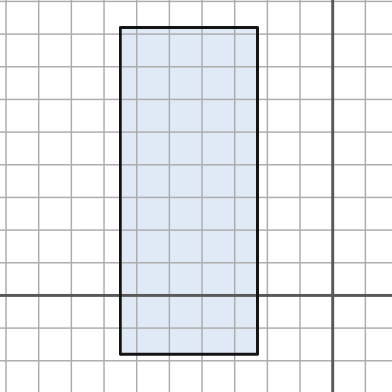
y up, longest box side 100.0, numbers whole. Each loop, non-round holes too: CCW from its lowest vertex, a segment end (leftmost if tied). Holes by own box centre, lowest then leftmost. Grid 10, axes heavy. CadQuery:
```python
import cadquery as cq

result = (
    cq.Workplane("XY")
    .moveTo(-65.0, -18.0)
    .lineTo(-23.0, -18.0)
    .lineTo(-23.0, 82.0)
    .lineTo(-65.0, 82.0)
    .close()
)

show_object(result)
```